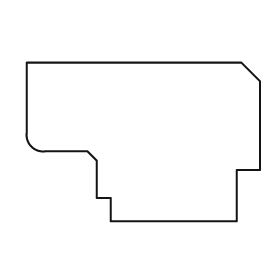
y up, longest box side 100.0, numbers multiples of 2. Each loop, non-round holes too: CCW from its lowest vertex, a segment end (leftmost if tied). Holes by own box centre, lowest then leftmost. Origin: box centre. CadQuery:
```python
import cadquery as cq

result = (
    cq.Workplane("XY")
    .moveTo(-14.0, -34.0)
    .lineTo(40.0, -34.0)
    .lineTo(40.0, -12.0)
    .lineTo(50.0, -12.0)
    .lineTo(50.0, 26.0)
    .lineTo(42.0, 34.0)
    .lineTo(-50.0, 34.0)
    .lineTo(-50.0, 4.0)
    .threePointArc((-48.0, -2.0), (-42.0, -4.0))
    .lineTo(-24.0, -4.0)
    .lineTo(-20.0, -8.0)
    .lineTo(-20.0, -24.0)
    .lineTo(-14.0, -24.0)
    .close()
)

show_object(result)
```